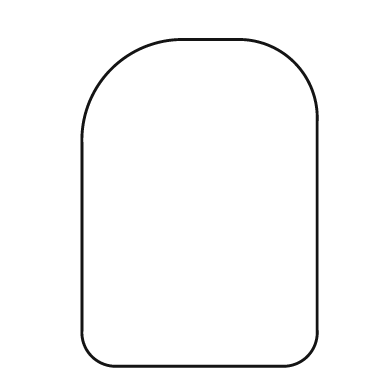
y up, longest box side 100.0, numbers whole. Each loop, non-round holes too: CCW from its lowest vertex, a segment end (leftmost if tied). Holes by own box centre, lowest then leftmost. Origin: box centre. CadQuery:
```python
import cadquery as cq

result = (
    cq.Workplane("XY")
    .moveTo(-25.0, -50.0)
    .lineTo(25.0, -50.0)
    .threePointArc((33.0, -47.0), (36.0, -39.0))
    .lineTo(36.0, 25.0)
    .threePointArc((29.0, 43.0), (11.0, 50.0))
    .lineTo(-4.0, 50.0)
    .threePointArc((-27.0, 41.0), (-36.0, 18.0))
    .lineTo(-36.0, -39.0)
    .threePointArc((-33.0, -47.0), (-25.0, -50.0))
    .close()
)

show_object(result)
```